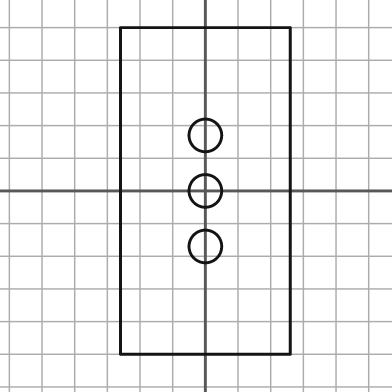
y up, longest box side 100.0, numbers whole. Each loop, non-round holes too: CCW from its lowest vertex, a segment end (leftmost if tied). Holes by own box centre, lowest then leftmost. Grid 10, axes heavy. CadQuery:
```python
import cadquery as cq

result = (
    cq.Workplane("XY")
    .moveTo(-26.0, -50.0)
    .lineTo(26.0, -50.0)
    .lineTo(26.0, 50.0)
    .lineTo(-26.0, 50.0)
    .close()
    .moveTo(0.0, -17.0)
    .circle(5.0)
    .moveTo(0.0, 0.0)
    .circle(5.0)
    .moveTo(0.0, 17.0)
    .circle(5.0)
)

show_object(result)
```